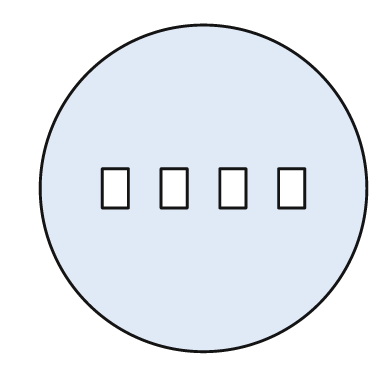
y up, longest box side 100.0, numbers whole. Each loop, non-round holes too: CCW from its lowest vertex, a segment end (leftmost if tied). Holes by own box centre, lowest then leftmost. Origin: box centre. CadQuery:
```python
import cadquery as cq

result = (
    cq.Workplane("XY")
    .moveTo(0.0, 0.0)
    .circle(50.0)
    .moveTo(-31.0, -6.0)
    .lineTo(-23.0, -6.0)
    .lineTo(-23.0, 6.0)
    .lineTo(-31.0, 6.0)
    .close()
    .moveTo(-13.0, -6.0)
    .lineTo(-5.0, -6.0)
    .lineTo(-5.0, 6.0)
    .lineTo(-13.0, 6.0)
    .close()
    .moveTo(5.0, -6.0)
    .lineTo(13.0, -6.0)
    .lineTo(13.0, 6.0)
    .lineTo(5.0, 6.0)
    .close()
    .moveTo(23.0, -6.0)
    .lineTo(31.0, -6.0)
    .lineTo(31.0, 6.0)
    .lineTo(23.0, 6.0)
    .close()
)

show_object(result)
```